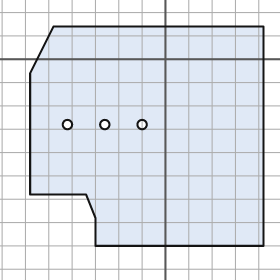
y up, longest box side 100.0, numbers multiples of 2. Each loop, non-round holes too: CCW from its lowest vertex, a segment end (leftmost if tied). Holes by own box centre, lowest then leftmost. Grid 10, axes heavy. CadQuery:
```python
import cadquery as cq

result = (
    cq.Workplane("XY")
    .moveTo(-30.0, -80.0)
    .lineTo(42.0, -80.0)
    .lineTo(42.0, 14.0)
    .lineTo(-48.0, 14.0)
    .lineTo(-58.0, -6.0)
    .lineTo(-58.0, -58.0)
    .lineTo(-34.0, -58.0)
    .lineTo(-30.0, -68.0)
    .close()
    .moveTo(-42.0, -28.0)
    .circle(2.0)
    .moveTo(-26.0, -28.0)
    .circle(2.0)
    .moveTo(-10.0, -28.0)
    .circle(2.0)
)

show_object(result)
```